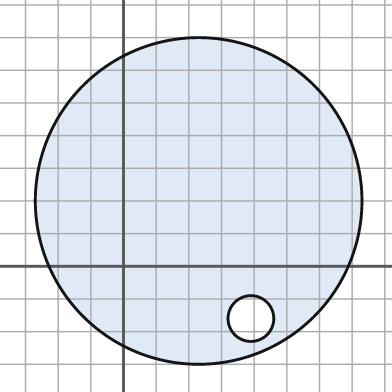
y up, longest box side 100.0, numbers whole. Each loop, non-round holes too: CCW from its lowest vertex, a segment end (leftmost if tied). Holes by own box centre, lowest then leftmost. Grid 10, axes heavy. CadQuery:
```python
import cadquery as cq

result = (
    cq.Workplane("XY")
    .moveTo(23.0, 20.0)
    .circle(50.0)
    .moveTo(39.0, -16.0)
    .circle(7.0)
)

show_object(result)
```